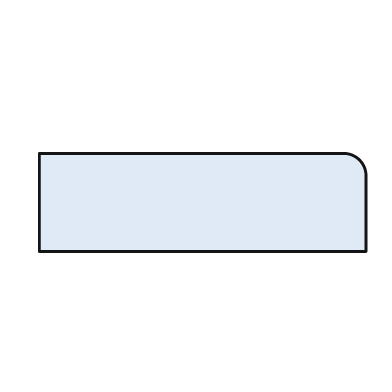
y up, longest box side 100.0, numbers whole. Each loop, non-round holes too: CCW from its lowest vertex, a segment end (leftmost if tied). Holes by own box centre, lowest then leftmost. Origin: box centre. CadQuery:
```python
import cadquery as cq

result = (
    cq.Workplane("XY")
    .moveTo(-50.0, -15.0)
    .lineTo(50.0, -15.0)
    .lineTo(50.0, 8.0)
    .threePointArc((48.0, 13.0), (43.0, 15.0))
    .lineTo(-50.0, 15.0)
    .close()
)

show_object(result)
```